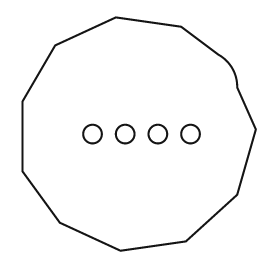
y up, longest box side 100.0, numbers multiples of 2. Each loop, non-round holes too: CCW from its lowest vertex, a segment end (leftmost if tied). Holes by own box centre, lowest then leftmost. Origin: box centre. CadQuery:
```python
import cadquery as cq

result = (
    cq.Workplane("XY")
    .moveTo(-8.0, -50.0)
    .lineTo(20.0, -46.0)
    .lineTo(42.0, -26.0)
    .lineTo(50.0, 2.0)
    .lineTo(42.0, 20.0)
    .threePointArc((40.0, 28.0), (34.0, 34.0))
    .lineTo(18.0, 46.0)
    .lineTo(-10.0, 50.0)
    .lineTo(-36.0, 38.0)
    .lineTo(-50.0, 14.0)
    .lineTo(-50.0, -16.0)
    .lineTo(-34.0, -38.0)
    .close()
    .moveTo(-20.0, 0.0)
    .circle(4.0)
    .moveTo(-6.0, 0.0)
    .circle(4.0)
    .moveTo(8.0, 0.0)
    .circle(4.0)
    .moveTo(22.0, 0.0)
    .circle(4.0)
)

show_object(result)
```